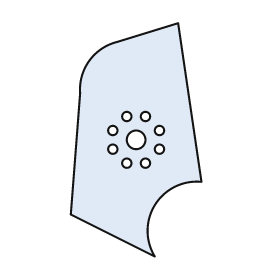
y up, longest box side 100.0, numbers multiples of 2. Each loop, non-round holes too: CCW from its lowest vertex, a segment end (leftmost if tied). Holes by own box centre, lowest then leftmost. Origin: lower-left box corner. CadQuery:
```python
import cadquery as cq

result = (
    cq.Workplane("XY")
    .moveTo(36.0, 0.0)
    .threePointArc((36.0, 22.0), (56.0, 32.0))
    .lineTo(46.0, 100.0)
    .lineTo(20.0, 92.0)
    .threePointArc((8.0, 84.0), (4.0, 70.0))
    .lineTo(0.0, 18.0)
    .close()
    .moveTo(24.0, 40.0)
    .circle(2.0)
    .moveTo(32.0, 40.0)
    .circle(2.0)
    .moveTo(18.0, 46.0)
    .circle(2.0)
    .moveTo(38.0, 46.0)
    .circle(2.0)
    .moveTo(28.0, 50.0)
    .circle(4.0)
    .moveTo(18.0, 54.0)
    .circle(2.0)
    .moveTo(38.0, 54.0)
    .circle(2.0)
    .moveTo(24.0, 60.0)
    .circle(2.0)
    .moveTo(32.0, 60.0)
    .circle(2.0)
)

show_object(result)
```